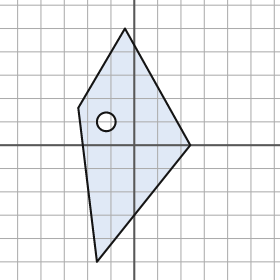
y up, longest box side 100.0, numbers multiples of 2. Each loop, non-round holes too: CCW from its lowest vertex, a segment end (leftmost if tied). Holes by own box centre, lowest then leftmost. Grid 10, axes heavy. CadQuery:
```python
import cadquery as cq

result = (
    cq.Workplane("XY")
    .moveTo(-16.0, -50.0)
    .lineTo(24.0, 0.0)
    .lineTo(-4.0, 50.0)
    .lineTo(-24.0, 16.0)
    .close()
    .moveTo(-12.0, 10.0)
    .circle(4.0)
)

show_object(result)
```